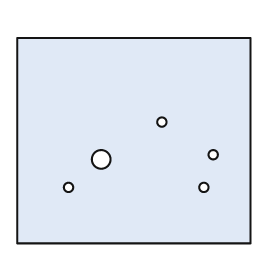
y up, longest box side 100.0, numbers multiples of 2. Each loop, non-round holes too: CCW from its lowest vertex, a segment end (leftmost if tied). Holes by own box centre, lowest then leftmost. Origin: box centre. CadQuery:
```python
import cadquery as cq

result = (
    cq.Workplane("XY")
    .moveTo(-50.0, -44.0)
    .lineTo(50.0, -44.0)
    .lineTo(50.0, 44.0)
    .lineTo(-50.0, 44.0)
    .close()
    .moveTo(-28.0, -20.0)
    .circle(2.0)
    .moveTo(30.0, -20.0)
    .circle(2.0)
    .moveTo(-14.0, -8.0)
    .circle(4.0)
    .moveTo(34.0, -6.0)
    .circle(2.0)
    .moveTo(12.0, 8.0)
    .circle(2.0)
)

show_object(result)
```